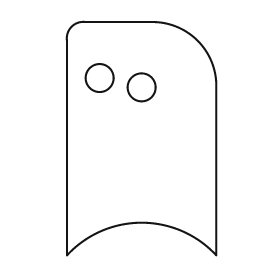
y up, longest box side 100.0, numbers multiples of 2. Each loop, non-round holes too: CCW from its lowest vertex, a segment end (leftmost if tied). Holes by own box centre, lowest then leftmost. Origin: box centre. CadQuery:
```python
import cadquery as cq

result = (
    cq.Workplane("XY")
    .moveTo(-32.0, -50.0)
    .threePointArc((0.0, -36.0), (32.0, -50.0))
    .lineTo(32.0, 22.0)
    .threePointArc((24.0, 42.0), (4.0, 50.0))
    .lineTo(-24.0, 50.0)
    .threePointArc((-30.0, 48.0), (-32.0, 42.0))
    .close()
    .moveTo(0.0, 22.0)
    .circle(6.0)
    .moveTo(-18.0, 26.0)
    .circle(6.0)
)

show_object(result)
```